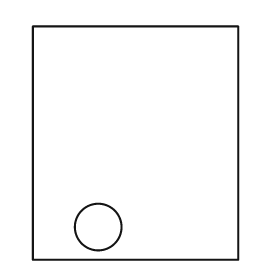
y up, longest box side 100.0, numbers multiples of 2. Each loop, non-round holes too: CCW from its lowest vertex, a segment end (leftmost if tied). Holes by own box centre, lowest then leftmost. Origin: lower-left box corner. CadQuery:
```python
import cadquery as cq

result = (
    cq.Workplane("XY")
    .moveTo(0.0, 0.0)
    .lineTo(88.0, 0.0)
    .lineTo(88.0, 100.0)
    .lineTo(0.0, 100.0)
    .close()
    .moveTo(28.0, 14.0)
    .circle(10.0)
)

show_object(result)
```